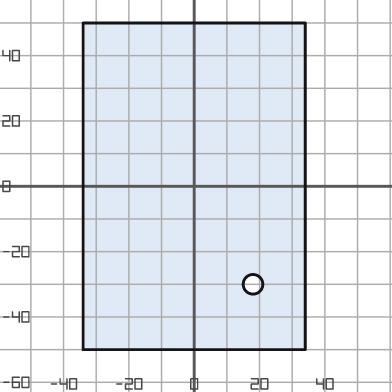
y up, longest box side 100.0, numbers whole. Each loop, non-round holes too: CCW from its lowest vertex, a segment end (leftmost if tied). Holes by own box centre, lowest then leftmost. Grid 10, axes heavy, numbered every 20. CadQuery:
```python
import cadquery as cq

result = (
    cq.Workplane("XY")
    .moveTo(-34.0, -50.0)
    .lineTo(34.0, -50.0)
    .lineTo(34.0, 50.0)
    .lineTo(-34.0, 50.0)
    .close()
    .moveTo(18.0, -30.0)
    .circle(3.0)
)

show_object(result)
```